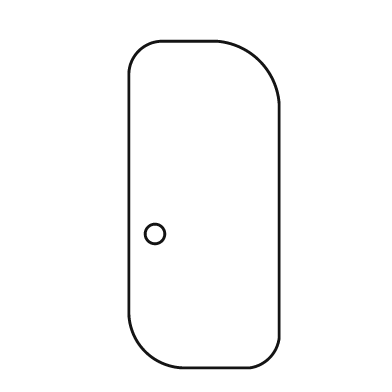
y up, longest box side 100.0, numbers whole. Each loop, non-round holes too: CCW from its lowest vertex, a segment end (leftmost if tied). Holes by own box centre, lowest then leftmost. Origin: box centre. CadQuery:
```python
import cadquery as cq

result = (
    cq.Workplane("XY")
    .moveTo(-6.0, -50.0)
    .lineTo(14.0, -50.0)
    .threePointArc((20.0, -47.0), (23.0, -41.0))
    .lineTo(23.0, 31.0)
    .threePointArc((17.0, 44.0), (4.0, 50.0))
    .lineTo(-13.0, 50.0)
    .threePointArc((-20.0, 47.0), (-23.0, 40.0))
    .lineTo(-23.0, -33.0)
    .threePointArc((-18.0, -45.0), (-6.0, -50.0))
    .close()
    .moveTo(-15.0, -9.0)
    .circle(3.0)
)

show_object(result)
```